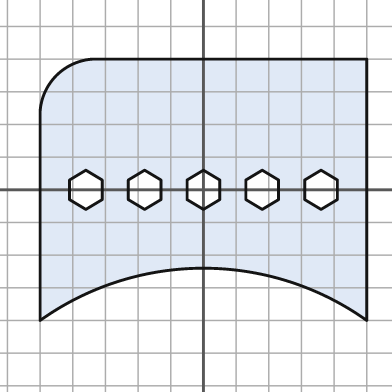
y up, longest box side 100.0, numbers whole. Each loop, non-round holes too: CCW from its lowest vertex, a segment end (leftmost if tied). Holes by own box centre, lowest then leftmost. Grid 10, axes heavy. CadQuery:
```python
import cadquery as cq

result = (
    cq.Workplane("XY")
    .moveTo(-50.0, -40.0)
    .threePointArc((0.0, -24.0), (50.0, -40.0))
    .lineTo(50.0, 40.0)
    .lineTo(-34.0, 40.0)
    .threePointArc((-45.0, 35.0), (-50.0, 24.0))
    .close()
    .moveTo(-36.0, -6.0)
    .lineTo(-31.0, -3.0)
    .lineTo(-31.0, 3.0)
    .lineTo(-36.0, 6.0)
    .lineTo(-41.0, 3.0)
    .lineTo(-41.0, -3.0)
    .close()
    .moveTo(-18.0, -6.0)
    .lineTo(-13.0, -3.0)
    .lineTo(-13.0, 3.0)
    .lineTo(-18.0, 6.0)
    .lineTo(-23.0, 3.0)
    .lineTo(-23.0, -3.0)
    .close()
    .moveTo(0.0, -6.0)
    .lineTo(5.0, -3.0)
    .lineTo(5.0, 3.0)
    .lineTo(0.0, 6.0)
    .lineTo(-5.0, 3.0)
    .lineTo(-5.0, -3.0)
    .close()
    .moveTo(18.0, -6.0)
    .lineTo(23.0, -3.0)
    .lineTo(23.0, 3.0)
    .lineTo(18.0, 6.0)
    .lineTo(13.0, 3.0)
    .lineTo(13.0, -3.0)
    .close()
    .moveTo(36.0, -6.0)
    .lineTo(41.0, -3.0)
    .lineTo(41.0, 3.0)
    .lineTo(36.0, 6.0)
    .lineTo(31.0, 3.0)
    .lineTo(31.0, -3.0)
    .close()
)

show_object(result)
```